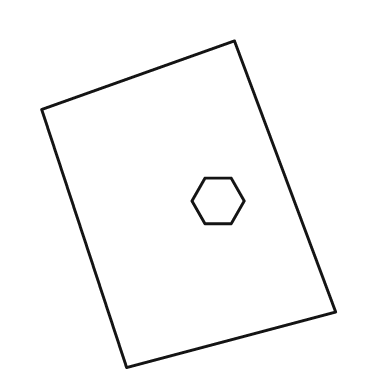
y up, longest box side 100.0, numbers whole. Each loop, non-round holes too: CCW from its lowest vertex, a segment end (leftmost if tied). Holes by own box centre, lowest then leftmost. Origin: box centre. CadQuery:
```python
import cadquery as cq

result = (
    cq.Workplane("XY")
    .moveTo(-19.0, -50.0)
    .lineTo(45.0, -33.0)
    .lineTo(14.0, 50.0)
    .lineTo(-45.0, 29.0)
    .close()
    .moveTo(5.0, -6.0)
    .lineTo(13.0, -6.0)
    .lineTo(17.0, 1.0)
    .lineTo(13.0, 8.0)
    .lineTo(5.0, 8.0)
    .lineTo(1.0, 1.0)
    .close()
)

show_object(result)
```